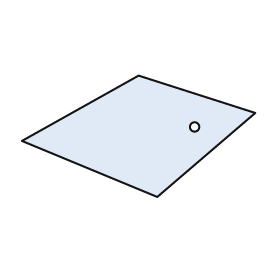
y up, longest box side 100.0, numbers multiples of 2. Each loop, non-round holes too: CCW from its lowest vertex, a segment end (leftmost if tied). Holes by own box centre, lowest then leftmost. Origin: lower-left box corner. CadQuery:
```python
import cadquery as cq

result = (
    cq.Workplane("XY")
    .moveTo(58.0, 0.0)
    .lineTo(100.0, 36.0)
    .lineTo(50.0, 52.0)
    .lineTo(0.0, 24.0)
    .close()
    .moveTo(74.0, 30.0)
    .circle(2.0)
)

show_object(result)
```